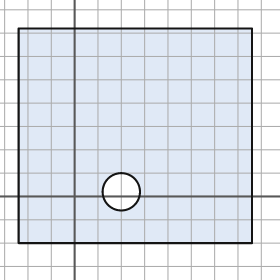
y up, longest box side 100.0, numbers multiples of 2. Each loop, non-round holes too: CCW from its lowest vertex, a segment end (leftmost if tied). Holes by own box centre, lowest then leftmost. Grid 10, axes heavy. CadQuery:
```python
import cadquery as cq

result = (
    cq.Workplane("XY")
    .moveTo(-24.0, -20.0)
    .lineTo(76.0, -20.0)
    .lineTo(76.0, 72.0)
    .lineTo(-24.0, 72.0)
    .close()
    .moveTo(20.0, 2.0)
    .circle(8.0)
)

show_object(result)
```